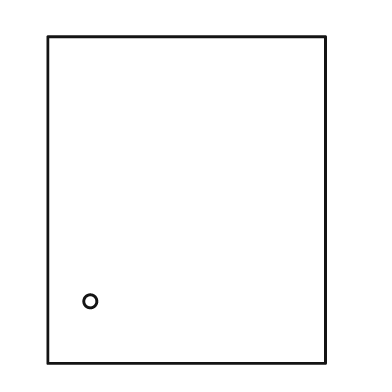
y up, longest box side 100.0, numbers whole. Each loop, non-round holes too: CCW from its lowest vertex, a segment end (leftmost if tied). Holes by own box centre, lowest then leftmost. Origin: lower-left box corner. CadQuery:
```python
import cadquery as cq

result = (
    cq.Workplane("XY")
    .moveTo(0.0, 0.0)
    .lineTo(85.0, 0.0)
    .lineTo(85.0, 100.0)
    .lineTo(0.0, 100.0)
    .close()
    .moveTo(13.0, 19.0)
    .circle(2.0)
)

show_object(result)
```